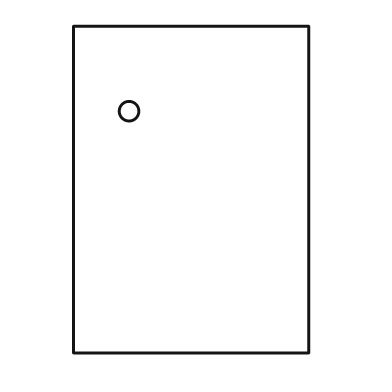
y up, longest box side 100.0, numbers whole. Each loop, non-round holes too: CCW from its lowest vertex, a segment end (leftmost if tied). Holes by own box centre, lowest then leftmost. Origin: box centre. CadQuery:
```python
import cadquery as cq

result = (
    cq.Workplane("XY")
    .moveTo(-36.0, -50.0)
    .lineTo(36.0, -50.0)
    .lineTo(36.0, 50.0)
    .lineTo(-36.0, 50.0)
    .close()
    .moveTo(-19.0, 24.0)
    .circle(3.0)
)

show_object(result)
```